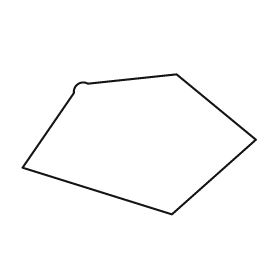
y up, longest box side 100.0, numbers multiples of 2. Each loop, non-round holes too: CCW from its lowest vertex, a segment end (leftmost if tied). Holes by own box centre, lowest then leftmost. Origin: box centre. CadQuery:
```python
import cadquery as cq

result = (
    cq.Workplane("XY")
    .moveTo(14.0, -30.0)
    .lineTo(50.0, 2.0)
    .lineTo(16.0, 30.0)
    .lineTo(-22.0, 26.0)
    .threePointArc((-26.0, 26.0), (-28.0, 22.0))
    .lineTo(-50.0, -10.0)
    .close()
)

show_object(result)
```